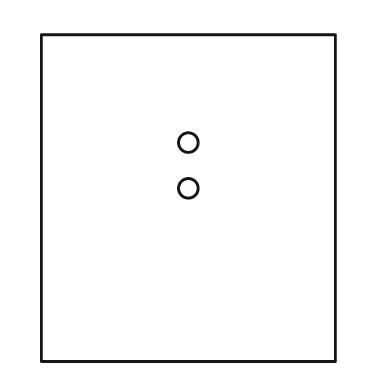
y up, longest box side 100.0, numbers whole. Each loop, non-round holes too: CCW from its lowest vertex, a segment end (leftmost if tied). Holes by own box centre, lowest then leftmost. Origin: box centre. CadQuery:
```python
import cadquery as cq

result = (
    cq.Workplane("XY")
    .moveTo(-45.0, -50.0)
    .lineTo(45.0, -50.0)
    .lineTo(45.0, 50.0)
    .lineTo(-45.0, 50.0)
    .close()
    .moveTo(0.0, 3.0)
    .circle(3.0)
    .moveTo(0.0, 17.0)
    .circle(3.0)
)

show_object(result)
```